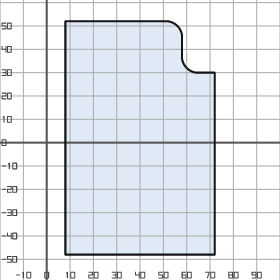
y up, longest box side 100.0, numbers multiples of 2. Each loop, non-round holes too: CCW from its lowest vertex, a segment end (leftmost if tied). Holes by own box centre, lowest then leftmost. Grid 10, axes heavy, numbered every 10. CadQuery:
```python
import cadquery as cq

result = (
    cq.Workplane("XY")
    .moveTo(8.0, -48.0)
    .lineTo(72.0, -48.0)
    .lineTo(72.0, 30.0)
    .lineTo(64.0, 30.0)
    .threePointArc((60.0, 32.0), (58.0, 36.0))
    .lineTo(58.0, 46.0)
    .threePointArc((56.0, 50.0), (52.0, 52.0))
    .lineTo(8.0, 52.0)
    .close()
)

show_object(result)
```